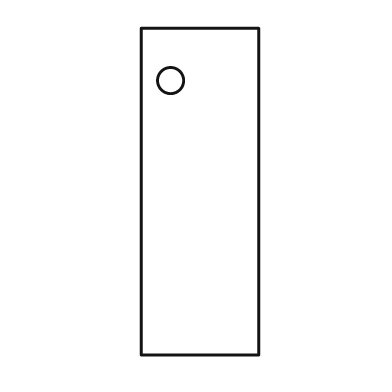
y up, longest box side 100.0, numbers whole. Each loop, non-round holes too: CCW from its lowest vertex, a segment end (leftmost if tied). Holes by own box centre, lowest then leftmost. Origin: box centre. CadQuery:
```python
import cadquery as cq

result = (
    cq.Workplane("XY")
    .moveTo(-18.0, -50.0)
    .lineTo(18.0, -50.0)
    .lineTo(18.0, 50.0)
    .lineTo(-18.0, 50.0)
    .close()
    .moveTo(-9.0, 34.0)
    .circle(4.0)
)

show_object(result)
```